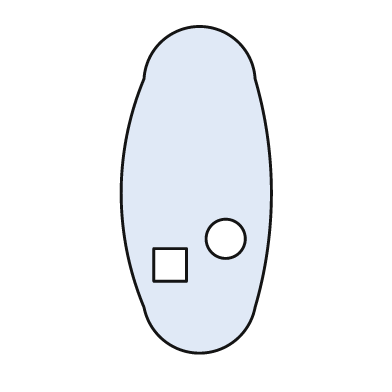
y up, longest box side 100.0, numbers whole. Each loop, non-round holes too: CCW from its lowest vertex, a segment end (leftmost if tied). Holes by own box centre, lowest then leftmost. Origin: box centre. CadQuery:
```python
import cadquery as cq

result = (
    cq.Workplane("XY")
    .moveTo(-16.0, -36.0)
    .threePointArc((1.0, -50.0), (18.0, -36.0))
    .threePointArc((23.0, -1.0), (18.0, 34.0))
    .threePointArc((1.0, 50.0), (-16.0, 34.0))
    .threePointArc((-23.0, -1.0), (-16.0, -36.0))
    .close()
    .moveTo(-13.0, -28.0)
    .lineTo(-3.0, -28.0)
    .lineTo(-3.0, -18.0)
    .lineTo(-13.0, -18.0)
    .close()
    .moveTo(9.0, -15.0)
    .circle(6.0)
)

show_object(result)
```